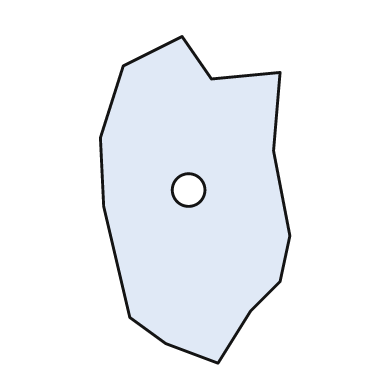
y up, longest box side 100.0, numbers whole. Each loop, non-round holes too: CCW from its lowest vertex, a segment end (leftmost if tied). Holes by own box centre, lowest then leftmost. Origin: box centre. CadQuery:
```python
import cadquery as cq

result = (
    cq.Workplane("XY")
    .moveTo(7.0, -50.0)
    .lineTo(17.0, -34.0)
    .lineTo(26.0, -25.0)
    .lineTo(29.0, -11.0)
    .lineTo(24.0, 15.0)
    .lineTo(26.0, 39.0)
    .lineTo(5.0, 37.0)
    .lineTo(-4.0, 50.0)
    .lineTo(-22.0, 41.0)
    .lineTo(-29.0, 19.0)
    .lineTo(-28.0, -2.0)
    .lineTo(-20.0, -36.0)
    .lineTo(-9.0, -44.0)
    .close()
    .moveTo(-2.0, 3.0)
    .circle(5.0)
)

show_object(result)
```